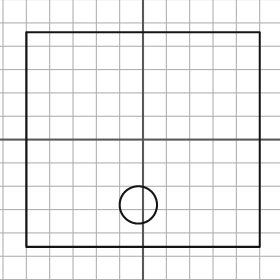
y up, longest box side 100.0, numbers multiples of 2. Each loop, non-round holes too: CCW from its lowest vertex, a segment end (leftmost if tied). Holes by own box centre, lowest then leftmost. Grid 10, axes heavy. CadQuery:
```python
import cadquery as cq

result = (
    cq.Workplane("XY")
    .moveTo(-50.0, -46.0)
    .lineTo(50.0, -46.0)
    .lineTo(50.0, 46.0)
    .lineTo(-50.0, 46.0)
    .close()
    .moveTo(-2.0, -28.0)
    .circle(8.0)
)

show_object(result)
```